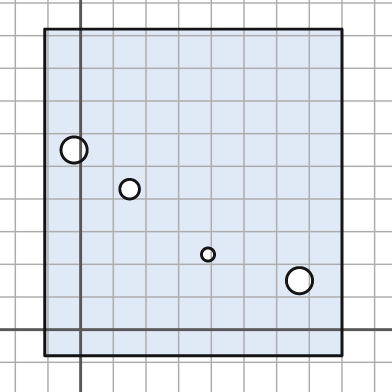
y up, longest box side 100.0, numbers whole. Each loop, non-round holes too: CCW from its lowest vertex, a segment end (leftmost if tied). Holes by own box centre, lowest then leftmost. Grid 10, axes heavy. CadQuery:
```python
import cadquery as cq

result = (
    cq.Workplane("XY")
    .moveTo(-11.0, -8.0)
    .lineTo(80.0, -8.0)
    .lineTo(80.0, 92.0)
    .lineTo(-11.0, 92.0)
    .close()
    .moveTo(67.0, 15.0)
    .circle(4.0)
    .moveTo(39.0, 23.0)
    .circle(2.0)
    .moveTo(15.0, 43.0)
    .circle(3.0)
    .moveTo(-2.0, 55.0)
    .circle(4.0)
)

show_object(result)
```